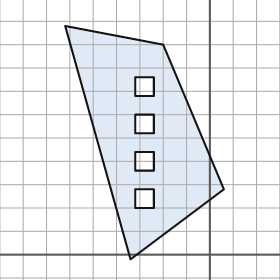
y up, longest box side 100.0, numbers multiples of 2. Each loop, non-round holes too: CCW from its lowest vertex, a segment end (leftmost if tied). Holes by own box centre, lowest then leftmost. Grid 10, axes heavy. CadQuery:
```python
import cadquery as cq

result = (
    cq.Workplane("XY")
    .moveTo(-34.0, -2.0)
    .lineTo(6.0, 28.0)
    .lineTo(-20.0, 90.0)
    .lineTo(-62.0, 98.0)
    .close()
    .moveTo(-32.0, 20.0)
    .lineTo(-24.0, 20.0)
    .lineTo(-24.0, 28.0)
    .lineTo(-32.0, 28.0)
    .close()
    .moveTo(-32.0, 36.0)
    .lineTo(-24.0, 36.0)
    .lineTo(-24.0, 44.0)
    .lineTo(-32.0, 44.0)
    .close()
    .moveTo(-32.0, 52.0)
    .lineTo(-24.0, 52.0)
    .lineTo(-24.0, 60.0)
    .lineTo(-32.0, 60.0)
    .close()
    .moveTo(-32.0, 68.0)
    .lineTo(-24.0, 68.0)
    .lineTo(-24.0, 76.0)
    .lineTo(-32.0, 76.0)
    .close()
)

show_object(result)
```